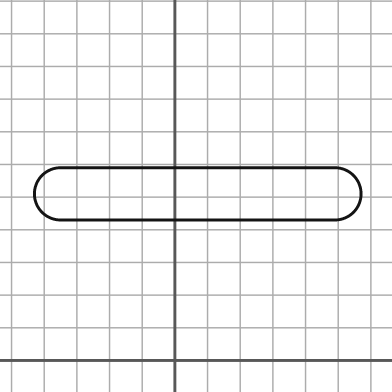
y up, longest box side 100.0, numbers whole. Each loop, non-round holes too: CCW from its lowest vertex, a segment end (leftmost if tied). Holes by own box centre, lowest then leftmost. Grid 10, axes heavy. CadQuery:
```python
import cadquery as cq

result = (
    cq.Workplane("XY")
    .moveTo(-35.0, 43.0)
    .lineTo(49.0, 43.0)
    .threePointArc((57.0, 51.0), (49.0, 59.0))
    .lineTo(-35.0, 59.0)
    .threePointArc((-43.0, 51.0), (-35.0, 43.0))
    .close()
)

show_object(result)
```